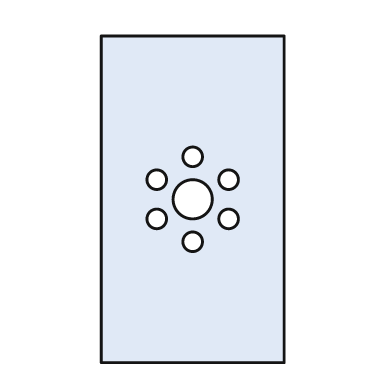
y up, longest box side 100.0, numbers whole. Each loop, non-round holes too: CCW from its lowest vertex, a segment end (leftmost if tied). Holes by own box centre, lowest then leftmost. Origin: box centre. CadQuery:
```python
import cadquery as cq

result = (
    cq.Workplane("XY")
    .moveTo(-28.0, -50.0)
    .lineTo(28.0, -50.0)
    .lineTo(28.0, 50.0)
    .lineTo(-28.0, 50.0)
    .close()
    .moveTo(0.0, -13.0)
    .circle(3.0)
    .moveTo(-11.0, -6.0)
    .circle(3.0)
    .moveTo(11.0, -6.0)
    .circle(3.0)
    .moveTo(0.0, 0.0)
    .circle(6.0)
    .moveTo(-11.0, 6.0)
    .circle(3.0)
    .moveTo(11.0, 6.0)
    .circle(3.0)
    .moveTo(0.0, 13.0)
    .circle(3.0)
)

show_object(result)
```